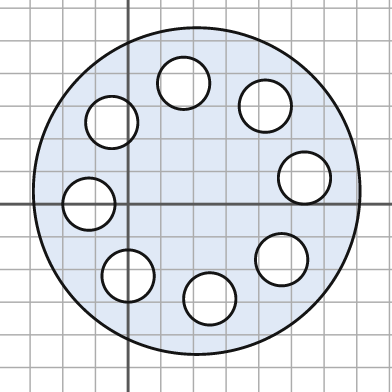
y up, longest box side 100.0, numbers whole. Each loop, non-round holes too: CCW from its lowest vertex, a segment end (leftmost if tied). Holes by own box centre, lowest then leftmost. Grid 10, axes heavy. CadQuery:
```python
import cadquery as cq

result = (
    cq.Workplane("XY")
    .moveTo(21.0, 4.0)
    .circle(50.0)
    .moveTo(25.0, -29.0)
    .circle(8.0)
    .moveTo(0.0, -22.0)
    .circle(8.0)
    .moveTo(47.0, -17.0)
    .circle(8.0)
    .moveTo(-12.0, 0.0)
    .circle(8.0)
    .moveTo(54.0, 8.0)
    .circle(8.0)
    .moveTo(-5.0, 25.0)
    .circle(8.0)
    .moveTo(42.0, 30.0)
    .circle(8.0)
    .moveTo(17.0, 37.0)
    .circle(8.0)
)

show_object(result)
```